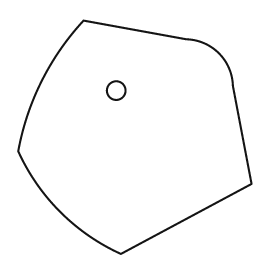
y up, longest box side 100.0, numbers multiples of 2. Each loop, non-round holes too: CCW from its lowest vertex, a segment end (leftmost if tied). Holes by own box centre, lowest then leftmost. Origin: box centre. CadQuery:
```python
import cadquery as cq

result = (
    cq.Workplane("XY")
    .moveTo(-6.0, -50.0)
    .lineTo(50.0, -20.0)
    .lineTo(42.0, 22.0)
    .threePointArc((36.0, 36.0), (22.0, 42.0))
    .lineTo(-22.0, 50.0)
    .threePointArc((-40.0, 24.0), (-50.0, -6.0))
    .threePointArc((-32.0, -32.0), (-6.0, -50.0))
    .close()
    .moveTo(-8.0, 20.0)
    .circle(4.0)
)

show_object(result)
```